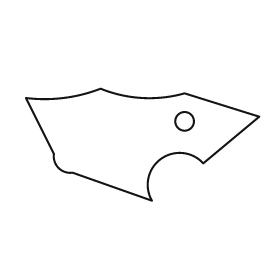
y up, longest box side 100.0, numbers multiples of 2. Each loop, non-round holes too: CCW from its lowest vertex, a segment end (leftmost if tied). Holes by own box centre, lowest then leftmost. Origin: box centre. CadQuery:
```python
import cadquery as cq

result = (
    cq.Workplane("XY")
    .moveTo(4.0, -24.0)
    .threePointArc((8.0, -6.0), (26.0, -8.0))
    .lineTo(50.0, 12.0)
    .lineTo(18.0, 22.0)
    .threePointArc((0.0, 20.0), (-18.0, 24.0))
    .threePointArc((-34.0, 20.0), (-50.0, 20.0))
    .lineTo(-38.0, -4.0)
    .threePointArc((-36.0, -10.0), (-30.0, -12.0))
    .close()
    .moveTo(18.0, 10.0)
    .circle(4.0)
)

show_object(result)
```